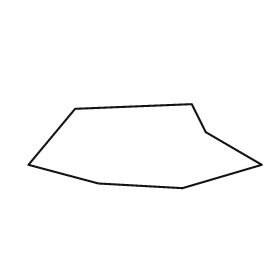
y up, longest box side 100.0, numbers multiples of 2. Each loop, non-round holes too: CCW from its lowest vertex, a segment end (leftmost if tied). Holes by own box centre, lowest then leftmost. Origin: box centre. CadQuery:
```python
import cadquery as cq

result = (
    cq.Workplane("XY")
    .moveTo(16.0, -18.0)
    .lineTo(50.0, -8.0)
    .lineTo(26.0, 6.0)
    .lineTo(20.0, 18.0)
    .lineTo(-30.0, 16.0)
    .lineTo(-50.0, -8.0)
    .lineTo(-20.0, -16.0)
    .close()
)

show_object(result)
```